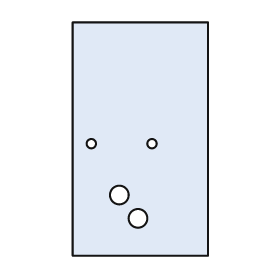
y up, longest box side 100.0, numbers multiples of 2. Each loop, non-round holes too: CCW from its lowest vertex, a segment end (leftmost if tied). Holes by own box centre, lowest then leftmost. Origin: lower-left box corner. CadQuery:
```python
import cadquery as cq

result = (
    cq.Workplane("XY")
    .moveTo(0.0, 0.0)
    .lineTo(58.0, 0.0)
    .lineTo(58.0, 100.0)
    .lineTo(0.0, 100.0)
    .close()
    .moveTo(28.0, 16.0)
    .circle(4.0)
    .moveTo(20.0, 26.0)
    .circle(4.0)
    .moveTo(8.0, 48.0)
    .circle(2.0)
    .moveTo(34.0, 48.0)
    .circle(2.0)
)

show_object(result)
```